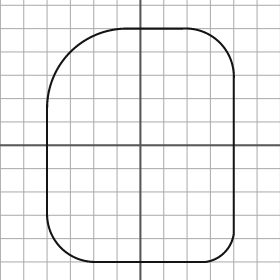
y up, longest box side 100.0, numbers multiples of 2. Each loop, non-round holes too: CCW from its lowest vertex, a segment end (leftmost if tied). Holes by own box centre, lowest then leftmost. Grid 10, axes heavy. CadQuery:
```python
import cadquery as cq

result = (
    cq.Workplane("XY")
    .moveTo(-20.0, -50.0)
    .lineTo(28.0, -50.0)
    .threePointArc((36.0, -46.0), (40.0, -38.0))
    .lineTo(40.0, 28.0)
    .threePointArc((34.0, 44.0), (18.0, 50.0))
    .lineTo(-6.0, 50.0)
    .threePointArc((-30.0, 40.0), (-40.0, 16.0))
    .lineTo(-40.0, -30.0)
    .threePointArc((-34.0, -44.0), (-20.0, -50.0))
    .close()
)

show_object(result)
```